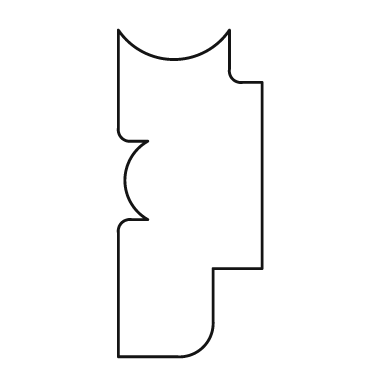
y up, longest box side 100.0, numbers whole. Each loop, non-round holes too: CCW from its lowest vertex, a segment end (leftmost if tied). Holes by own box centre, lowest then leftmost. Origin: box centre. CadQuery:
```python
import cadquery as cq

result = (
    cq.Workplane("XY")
    .moveTo(-22.0, -50.0)
    .lineTo(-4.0, -50.0)
    .threePointArc((4.0, -47.0), (7.0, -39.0))
    .lineTo(7.0, -23.0)
    .lineTo(22.0, -23.0)
    .lineTo(22.0, 34.0)
    .lineTo(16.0, 34.0)
    .threePointArc((13.0, 35.0), (12.0, 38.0))
    .lineTo(12.0, 50.0)
    .threePointArc((-5.0, 41.0), (-22.0, 50.0))
    .lineTo(-22.0, 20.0)
    .threePointArc((-21.0, 17.0), (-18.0, 16.0))
    .lineTo(-13.0, 16.0)
    .threePointArc((-20.0, 4.0), (-13.0, -8.0))
    .lineTo(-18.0, -8.0)
    .threePointArc((-21.0, -9.0), (-22.0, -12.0))
    .close()
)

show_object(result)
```